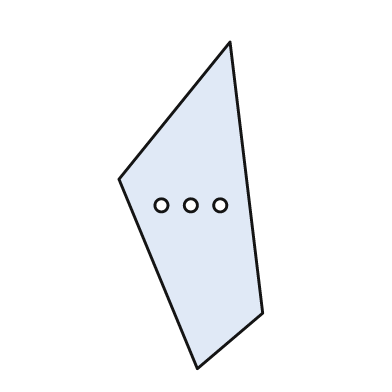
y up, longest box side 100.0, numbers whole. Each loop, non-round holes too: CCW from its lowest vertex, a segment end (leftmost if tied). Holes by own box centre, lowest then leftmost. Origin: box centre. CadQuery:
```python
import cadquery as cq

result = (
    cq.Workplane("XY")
    .moveTo(2.0, -50.0)
    .lineTo(22.0, -33.0)
    .lineTo(12.0, 50.0)
    .lineTo(-22.0, 8.0)
    .close()
    .moveTo(-9.0, 0.0)
    .circle(2.0)
    .moveTo(0.0, 0.0)
    .circle(2.0)
    .moveTo(9.0, 0.0)
    .circle(2.0)
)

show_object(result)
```